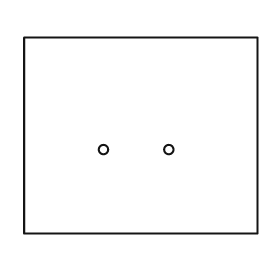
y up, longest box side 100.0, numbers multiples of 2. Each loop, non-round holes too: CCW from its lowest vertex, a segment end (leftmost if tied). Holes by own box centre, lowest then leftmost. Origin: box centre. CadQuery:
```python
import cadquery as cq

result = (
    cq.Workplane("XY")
    .moveTo(-50.0, -42.0)
    .lineTo(50.0, -42.0)
    .lineTo(50.0, 42.0)
    .lineTo(-50.0, 42.0)
    .close()
    .moveTo(-16.0, -6.0)
    .circle(2.0)
    .moveTo(12.0, -6.0)
    .circle(2.0)
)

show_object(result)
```